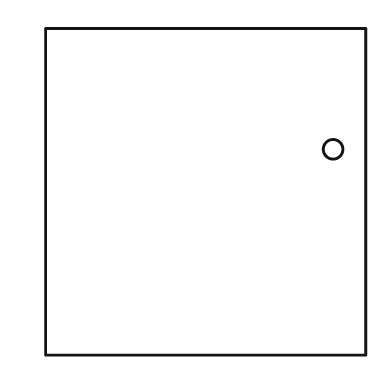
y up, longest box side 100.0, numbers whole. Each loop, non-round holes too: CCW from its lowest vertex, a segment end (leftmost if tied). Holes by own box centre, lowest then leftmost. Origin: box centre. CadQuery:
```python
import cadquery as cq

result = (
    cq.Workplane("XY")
    .moveTo(-49.0, -50.0)
    .lineTo(49.0, -50.0)
    .lineTo(49.0, 50.0)
    .lineTo(-49.0, 50.0)
    .close()
    .moveTo(39.0, 13.0)
    .circle(3.0)
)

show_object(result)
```